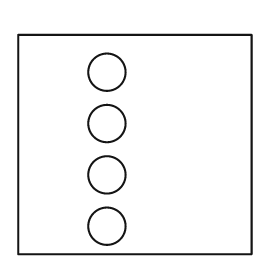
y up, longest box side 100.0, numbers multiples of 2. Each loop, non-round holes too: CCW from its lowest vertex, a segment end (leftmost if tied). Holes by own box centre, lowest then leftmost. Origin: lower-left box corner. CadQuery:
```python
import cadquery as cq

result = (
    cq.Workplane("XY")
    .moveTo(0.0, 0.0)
    .lineTo(100.0, 0.0)
    .lineTo(100.0, 94.0)
    .lineTo(0.0, 94.0)
    .close()
    .moveTo(38.0, 12.0)
    .circle(8.0)
    .moveTo(38.0, 34.0)
    .circle(8.0)
    .moveTo(38.0, 56.0)
    .circle(8.0)
    .moveTo(38.0, 78.0)
    .circle(8.0)
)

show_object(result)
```